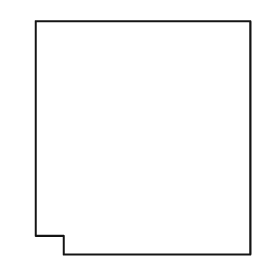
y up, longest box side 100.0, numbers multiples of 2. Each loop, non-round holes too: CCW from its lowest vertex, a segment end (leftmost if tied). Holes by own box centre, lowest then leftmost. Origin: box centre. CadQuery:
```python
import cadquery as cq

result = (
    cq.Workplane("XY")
    .moveTo(-34.0, -50.0)
    .lineTo(46.0, -50.0)
    .lineTo(46.0, 50.0)
    .lineTo(-46.0, 50.0)
    .lineTo(-46.0, -42.0)
    .lineTo(-34.0, -42.0)
    .close()
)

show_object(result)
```